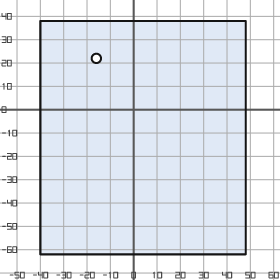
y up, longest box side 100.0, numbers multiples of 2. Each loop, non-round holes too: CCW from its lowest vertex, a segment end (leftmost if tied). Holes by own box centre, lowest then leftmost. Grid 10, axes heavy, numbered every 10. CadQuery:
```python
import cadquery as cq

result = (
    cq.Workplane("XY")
    .moveTo(-40.0, -62.0)
    .lineTo(48.0, -62.0)
    .lineTo(48.0, 38.0)
    .lineTo(-40.0, 38.0)
    .close()
    .moveTo(-16.0, 22.0)
    .circle(2.0)
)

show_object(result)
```